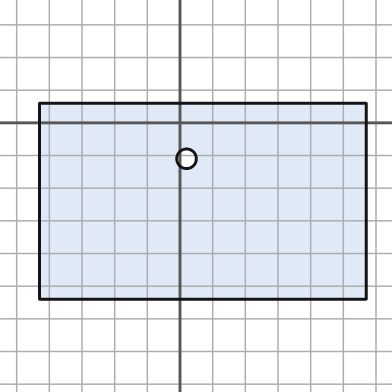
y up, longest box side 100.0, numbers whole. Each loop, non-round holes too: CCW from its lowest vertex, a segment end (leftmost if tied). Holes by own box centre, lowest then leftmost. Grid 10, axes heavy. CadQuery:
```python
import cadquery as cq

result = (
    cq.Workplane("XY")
    .moveTo(-43.0, -54.0)
    .lineTo(57.0, -54.0)
    .lineTo(57.0, 6.0)
    .lineTo(-43.0, 6.0)
    .close()
    .moveTo(2.0, -11.0)
    .circle(3.0)
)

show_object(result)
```